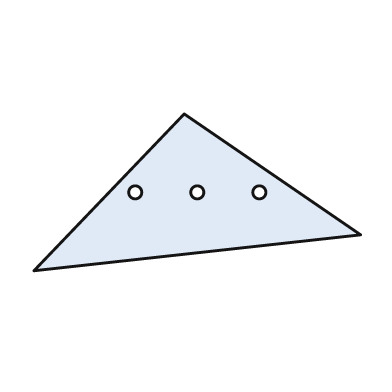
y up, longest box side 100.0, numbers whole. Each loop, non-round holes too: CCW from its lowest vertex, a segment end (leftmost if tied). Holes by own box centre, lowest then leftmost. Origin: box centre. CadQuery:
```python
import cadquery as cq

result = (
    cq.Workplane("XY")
    .moveTo(-50.0, -24.0)
    .lineTo(50.0, -13.0)
    .lineTo(-4.0, 24.0)
    .close()
    .moveTo(-19.0, 0.0)
    .circle(2.0)
    .moveTo(0.0, 0.0)
    .circle(2.0)
    .moveTo(19.0, 0.0)
    .circle(2.0)
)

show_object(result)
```